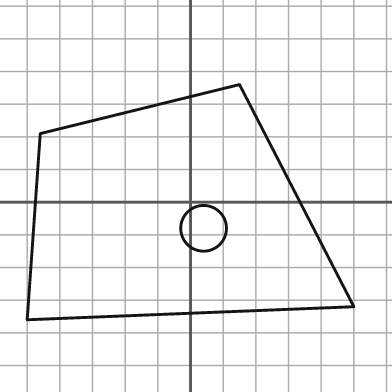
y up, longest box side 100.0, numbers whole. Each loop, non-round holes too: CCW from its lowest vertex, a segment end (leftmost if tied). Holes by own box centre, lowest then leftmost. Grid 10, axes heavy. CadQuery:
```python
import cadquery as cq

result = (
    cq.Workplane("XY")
    .moveTo(-50.0, -36.0)
    .lineTo(50.0, -32.0)
    .lineTo(15.0, 36.0)
    .lineTo(-46.0, 21.0)
    .close()
    .moveTo(4.0, -8.0)
    .circle(7.0)
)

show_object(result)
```